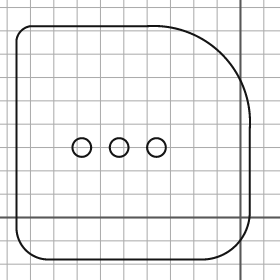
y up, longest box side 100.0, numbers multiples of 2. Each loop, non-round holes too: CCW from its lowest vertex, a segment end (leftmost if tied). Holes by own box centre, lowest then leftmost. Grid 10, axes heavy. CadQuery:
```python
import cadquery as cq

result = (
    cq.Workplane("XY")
    .moveTo(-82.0, -18.0)
    .lineTo(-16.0, -18.0)
    .threePointArc((-2.0, -12.0), (4.0, 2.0))
    .lineTo(4.0, 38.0)
    .threePointArc((-8.0, 70.0), (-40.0, 82.0))
    .lineTo(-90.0, 82.0)
    .threePointArc((-94.0, 80.0), (-96.0, 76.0))
    .lineTo(-96.0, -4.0)
    .threePointArc((-92.0, -14.0), (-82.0, -18.0))
    .close()
    .moveTo(-68.0, 30.0)
    .circle(4.0)
    .moveTo(-52.0, 30.0)
    .circle(4.0)
    .moveTo(-36.0, 30.0)
    .circle(4.0)
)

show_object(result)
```